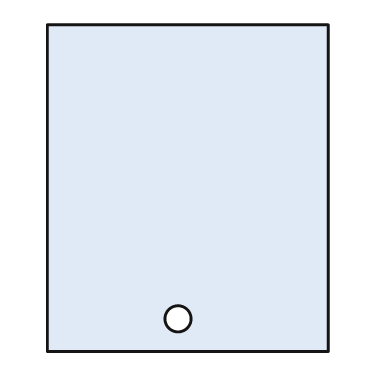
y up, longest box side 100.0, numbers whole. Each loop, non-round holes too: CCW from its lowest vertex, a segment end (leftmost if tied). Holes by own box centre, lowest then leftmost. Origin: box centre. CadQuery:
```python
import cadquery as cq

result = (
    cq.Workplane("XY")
    .moveTo(-43.0, -50.0)
    .lineTo(43.0, -50.0)
    .lineTo(43.0, 50.0)
    .lineTo(-43.0, 50.0)
    .close()
    .moveTo(-3.0, -40.0)
    .circle(4.0)
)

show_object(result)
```